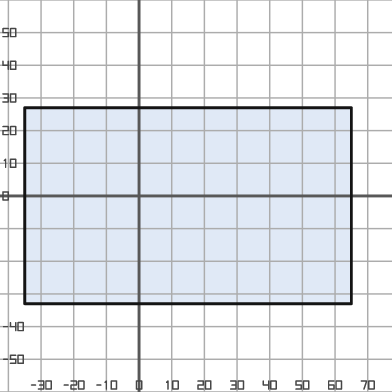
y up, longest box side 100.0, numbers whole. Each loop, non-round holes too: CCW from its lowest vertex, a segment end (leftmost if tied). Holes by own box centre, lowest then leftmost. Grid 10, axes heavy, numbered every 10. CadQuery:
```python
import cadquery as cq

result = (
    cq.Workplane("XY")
    .moveTo(-35.0, -33.0)
    .lineTo(65.0, -33.0)
    .lineTo(65.0, 27.0)
    .lineTo(-35.0, 27.0)
    .close()
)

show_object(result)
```